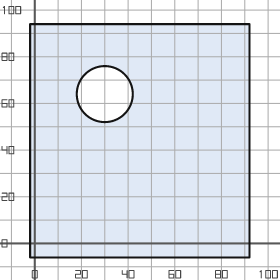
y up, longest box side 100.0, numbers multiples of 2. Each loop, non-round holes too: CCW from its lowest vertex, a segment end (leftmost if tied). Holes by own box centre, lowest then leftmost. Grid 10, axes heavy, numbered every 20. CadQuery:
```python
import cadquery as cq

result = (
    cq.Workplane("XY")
    .moveTo(-2.0, -6.0)
    .lineTo(92.0, -6.0)
    .lineTo(92.0, 94.0)
    .lineTo(-2.0, 94.0)
    .close()
    .moveTo(30.0, 64.0)
    .circle(12.0)
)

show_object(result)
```